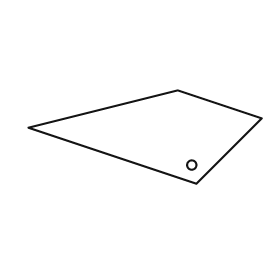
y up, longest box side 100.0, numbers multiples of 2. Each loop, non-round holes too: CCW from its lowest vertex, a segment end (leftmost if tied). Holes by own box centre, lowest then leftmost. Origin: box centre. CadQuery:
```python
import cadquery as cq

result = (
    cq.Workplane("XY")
    .moveTo(22.0, -20.0)
    .lineTo(50.0, 8.0)
    .lineTo(14.0, 20.0)
    .lineTo(-50.0, 4.0)
    .close()
    .moveTo(20.0, -12.0)
    .circle(2.0)
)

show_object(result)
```